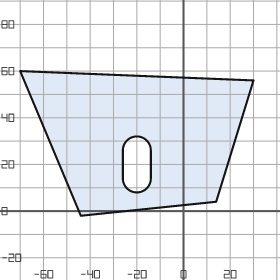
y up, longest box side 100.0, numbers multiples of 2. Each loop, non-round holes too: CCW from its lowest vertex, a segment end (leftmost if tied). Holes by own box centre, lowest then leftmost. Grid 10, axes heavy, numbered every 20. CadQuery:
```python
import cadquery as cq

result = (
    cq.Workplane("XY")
    .moveTo(-44.0, -2.0)
    .lineTo(14.0, 4.0)
    .lineTo(30.0, 56.0)
    .lineTo(-70.0, 60.0)
    .close()
    .moveTo(-26.0, 14.0)
    .threePointArc((-20.0, 8.0), (-14.0, 14.0))
    .lineTo(-14.0, 26.0)
    .threePointArc((-20.0, 32.0), (-26.0, 26.0))
    .close()
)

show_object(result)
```